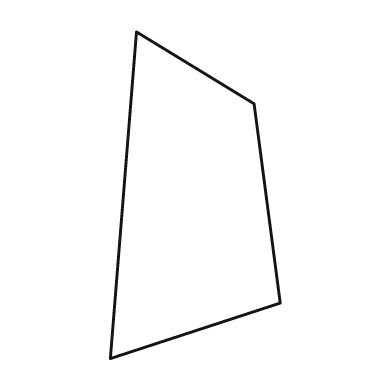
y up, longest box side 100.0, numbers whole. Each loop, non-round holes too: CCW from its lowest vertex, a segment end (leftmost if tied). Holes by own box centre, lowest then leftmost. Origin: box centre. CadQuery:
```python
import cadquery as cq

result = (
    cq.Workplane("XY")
    .moveTo(-26.0, -50.0)
    .lineTo(26.0, -33.0)
    .lineTo(18.0, 28.0)
    .lineTo(-18.0, 50.0)
    .close()
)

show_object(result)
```